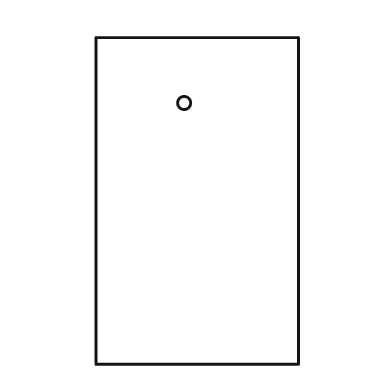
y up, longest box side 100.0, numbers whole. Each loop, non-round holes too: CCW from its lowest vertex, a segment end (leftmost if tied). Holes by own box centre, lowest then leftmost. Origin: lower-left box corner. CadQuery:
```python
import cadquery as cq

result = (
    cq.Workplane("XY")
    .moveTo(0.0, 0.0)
    .lineTo(62.0, 0.0)
    .lineTo(62.0, 100.0)
    .lineTo(0.0, 100.0)
    .close()
    .moveTo(27.0, 80.0)
    .circle(2.0)
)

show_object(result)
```